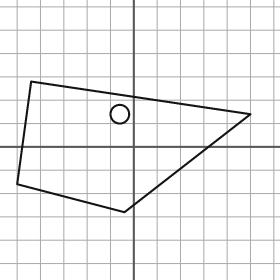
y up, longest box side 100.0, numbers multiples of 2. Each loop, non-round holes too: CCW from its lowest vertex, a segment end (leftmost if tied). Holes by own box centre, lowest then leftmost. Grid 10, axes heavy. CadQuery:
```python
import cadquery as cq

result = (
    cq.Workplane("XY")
    .moveTo(-4.0, -28.0)
    .lineTo(50.0, 14.0)
    .lineTo(-44.0, 28.0)
    .lineTo(-50.0, -16.0)
    .close()
    .moveTo(-6.0, 14.0)
    .circle(4.0)
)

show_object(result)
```